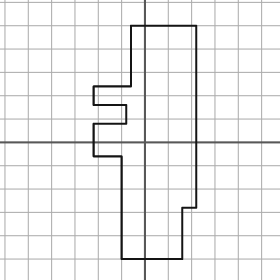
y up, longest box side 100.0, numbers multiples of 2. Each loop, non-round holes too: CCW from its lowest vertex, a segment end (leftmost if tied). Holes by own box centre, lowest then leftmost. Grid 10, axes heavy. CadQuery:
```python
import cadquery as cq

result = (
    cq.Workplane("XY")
    .moveTo(-10.0, -50.0)
    .lineTo(16.0, -50.0)
    .lineTo(16.0, -28.0)
    .lineTo(22.0, -28.0)
    .lineTo(22.0, 50.0)
    .lineTo(-6.0, 50.0)
    .lineTo(-6.0, 24.0)
    .lineTo(-22.0, 24.0)
    .lineTo(-22.0, 16.0)
    .lineTo(-8.0, 16.0)
    .lineTo(-8.0, 8.0)
    .lineTo(-22.0, 8.0)
    .lineTo(-22.0, -6.0)
    .lineTo(-10.0, -6.0)
    .close()
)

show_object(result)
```